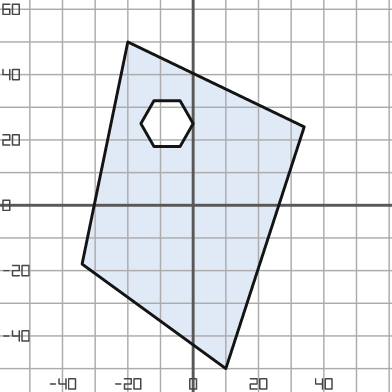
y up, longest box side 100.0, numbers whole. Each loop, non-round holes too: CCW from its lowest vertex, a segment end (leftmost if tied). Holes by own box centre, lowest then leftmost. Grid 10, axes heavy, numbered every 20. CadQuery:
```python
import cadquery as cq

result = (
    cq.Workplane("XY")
    .moveTo(10.0, -50.0)
    .lineTo(34.0, 24.0)
    .lineTo(-20.0, 50.0)
    .lineTo(-34.0, -18.0)
    .close()
    .moveTo(-12.0, 18.0)
    .lineTo(-4.0, 18.0)
    .lineTo(0.0, 25.0)
    .lineTo(-4.0, 32.0)
    .lineTo(-12.0, 32.0)
    .lineTo(-16.0, 25.0)
    .close()
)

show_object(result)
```